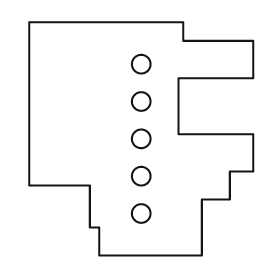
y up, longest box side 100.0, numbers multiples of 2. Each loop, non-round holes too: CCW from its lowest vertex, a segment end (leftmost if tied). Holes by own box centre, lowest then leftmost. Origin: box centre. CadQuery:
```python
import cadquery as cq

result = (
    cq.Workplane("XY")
    .moveTo(-18.0, -50.0)
    .lineTo(26.0, -50.0)
    .lineTo(26.0, -26.0)
    .lineTo(38.0, -26.0)
    .lineTo(38.0, -14.0)
    .lineTo(48.0, -14.0)
    .lineTo(48.0, 2.0)
    .lineTo(16.0, 2.0)
    .lineTo(16.0, 26.0)
    .lineTo(48.0, 26.0)
    .lineTo(48.0, 42.0)
    .lineTo(18.0, 42.0)
    .lineTo(18.0, 50.0)
    .lineTo(-48.0, 50.0)
    .lineTo(-48.0, -20.0)
    .lineTo(-22.0, -20.0)
    .lineTo(-22.0, -38.0)
    .lineTo(-18.0, -38.0)
    .close()
    .moveTo(0.0, -32.0)
    .circle(4.0)
    .moveTo(0.0, -16.0)
    .circle(4.0)
    .moveTo(0.0, 0.0)
    .circle(4.0)
    .moveTo(0.0, 16.0)
    .circle(4.0)
    .moveTo(0.0, 32.0)
    .circle(4.0)
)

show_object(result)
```